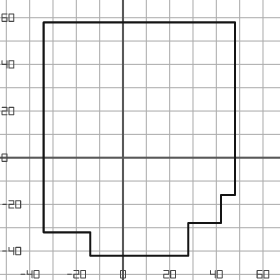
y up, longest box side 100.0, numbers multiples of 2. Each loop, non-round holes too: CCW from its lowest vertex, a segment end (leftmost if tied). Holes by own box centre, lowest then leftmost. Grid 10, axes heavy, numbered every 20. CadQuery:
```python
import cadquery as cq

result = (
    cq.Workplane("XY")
    .moveTo(-14.0, -42.0)
    .lineTo(28.0, -42.0)
    .lineTo(28.0, -28.0)
    .lineTo(42.0, -28.0)
    .lineTo(42.0, -16.0)
    .lineTo(48.0, -16.0)
    .lineTo(48.0, 58.0)
    .lineTo(-34.0, 58.0)
    .lineTo(-34.0, -32.0)
    .lineTo(-14.0, -32.0)
    .close()
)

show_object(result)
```